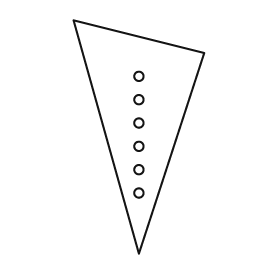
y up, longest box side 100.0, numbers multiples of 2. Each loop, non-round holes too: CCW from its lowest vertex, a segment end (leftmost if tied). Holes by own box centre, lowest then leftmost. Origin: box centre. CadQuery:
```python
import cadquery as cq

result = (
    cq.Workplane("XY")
    .moveTo(0.0, -50.0)
    .lineTo(28.0, 36.0)
    .lineTo(-28.0, 50.0)
    .close()
    .moveTo(0.0, -24.0)
    .circle(2.0)
    .moveTo(0.0, -14.0)
    .circle(2.0)
    .moveTo(0.0, -4.0)
    .circle(2.0)
    .moveTo(0.0, 6.0)
    .circle(2.0)
    .moveTo(0.0, 16.0)
    .circle(2.0)
    .moveTo(0.0, 26.0)
    .circle(2.0)
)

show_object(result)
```